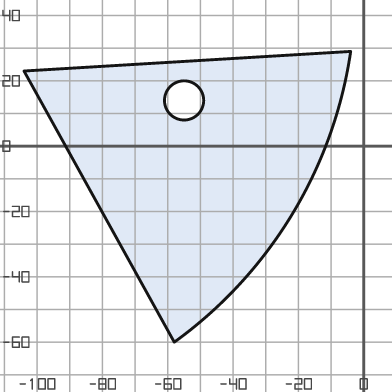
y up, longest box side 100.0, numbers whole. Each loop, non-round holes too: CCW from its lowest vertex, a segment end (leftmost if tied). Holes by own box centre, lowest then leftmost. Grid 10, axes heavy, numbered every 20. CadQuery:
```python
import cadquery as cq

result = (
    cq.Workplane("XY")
    .moveTo(-58.0, -60.0)
    .threePointArc((-22.0, -21.0), (-4.0, 29.0))
    .lineTo(-104.0, 23.0)
    .close()
    .moveTo(-55.0, 14.0)
    .circle(6.0)
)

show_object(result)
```